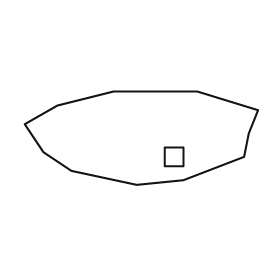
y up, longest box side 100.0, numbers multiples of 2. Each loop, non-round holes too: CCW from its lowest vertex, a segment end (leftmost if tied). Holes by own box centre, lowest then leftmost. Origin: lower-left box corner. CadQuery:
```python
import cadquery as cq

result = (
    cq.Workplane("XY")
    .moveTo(48.0, 0.0)
    .lineTo(68.0, 2.0)
    .lineTo(94.0, 12.0)
    .lineTo(96.0, 22.0)
    .lineTo(100.0, 32.0)
    .lineTo(74.0, 40.0)
    .lineTo(38.0, 40.0)
    .lineTo(14.0, 34.0)
    .lineTo(0.0, 26.0)
    .lineTo(8.0, 14.0)
    .lineTo(20.0, 6.0)
    .close()
    .moveTo(60.0, 8.0)
    .lineTo(68.0, 8.0)
    .lineTo(68.0, 16.0)
    .lineTo(60.0, 16.0)
    .close()
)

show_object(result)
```